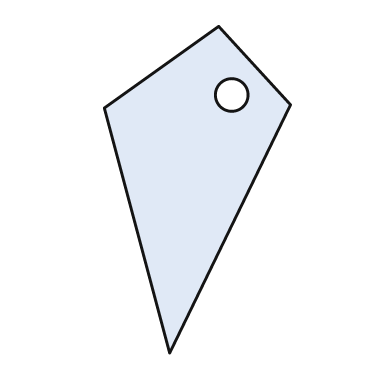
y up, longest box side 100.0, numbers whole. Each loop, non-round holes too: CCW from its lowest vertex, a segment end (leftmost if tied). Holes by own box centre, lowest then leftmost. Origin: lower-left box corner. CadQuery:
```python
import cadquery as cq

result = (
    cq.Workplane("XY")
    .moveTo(20.0, 0.0)
    .lineTo(57.0, 76.0)
    .lineTo(35.0, 100.0)
    .lineTo(0.0, 75.0)
    .close()
    .moveTo(39.0, 79.0)
    .circle(5.0)
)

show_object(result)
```